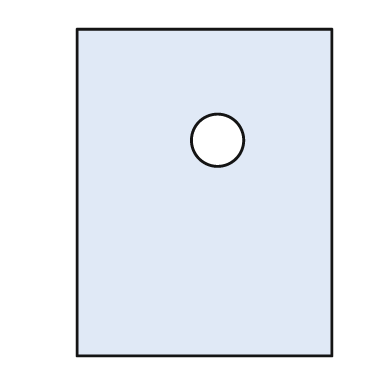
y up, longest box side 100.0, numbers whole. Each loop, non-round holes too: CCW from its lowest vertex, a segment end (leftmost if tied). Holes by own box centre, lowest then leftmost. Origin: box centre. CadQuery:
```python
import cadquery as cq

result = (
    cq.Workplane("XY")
    .moveTo(-39.0, -50.0)
    .lineTo(39.0, -50.0)
    .lineTo(39.0, 50.0)
    .lineTo(-39.0, 50.0)
    .close()
    .moveTo(4.0, 16.0)
    .circle(8.0)
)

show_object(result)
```